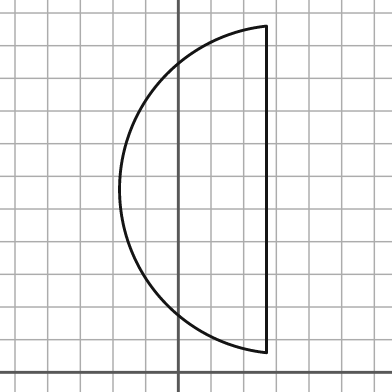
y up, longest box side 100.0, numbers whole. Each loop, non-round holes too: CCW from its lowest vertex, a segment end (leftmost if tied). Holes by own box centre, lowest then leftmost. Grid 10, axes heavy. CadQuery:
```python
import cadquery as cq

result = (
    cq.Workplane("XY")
    .moveTo(27.0, 6.0)
    .lineTo(27.0, 106.0)
    .threePointArc((-18.0, 56.0), (27.0, 6.0))
    .close()
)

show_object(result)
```